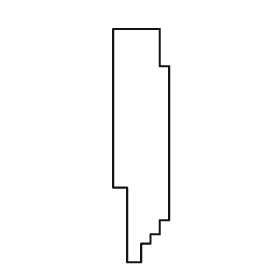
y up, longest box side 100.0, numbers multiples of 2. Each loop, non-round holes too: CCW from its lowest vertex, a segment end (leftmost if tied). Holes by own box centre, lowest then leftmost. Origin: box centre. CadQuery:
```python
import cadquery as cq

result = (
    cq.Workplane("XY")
    .moveTo(-6.0, -50.0)
    .lineTo(0.0, -50.0)
    .lineTo(0.0, -42.0)
    .lineTo(4.0, -42.0)
    .lineTo(4.0, -38.0)
    .lineTo(8.0, -38.0)
    .lineTo(8.0, -32.0)
    .lineTo(12.0, -32.0)
    .lineTo(12.0, 34.0)
    .lineTo(8.0, 34.0)
    .lineTo(8.0, 50.0)
    .lineTo(-12.0, 50.0)
    .lineTo(-12.0, -18.0)
    .lineTo(-6.0, -18.0)
    .close()
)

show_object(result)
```